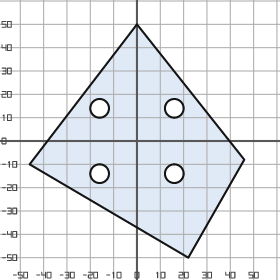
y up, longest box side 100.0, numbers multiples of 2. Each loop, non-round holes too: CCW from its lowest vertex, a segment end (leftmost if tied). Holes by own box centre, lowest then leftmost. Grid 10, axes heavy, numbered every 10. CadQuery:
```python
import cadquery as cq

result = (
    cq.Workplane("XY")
    .moveTo(22.0, -50.0)
    .lineTo(46.0, -8.0)
    .lineTo(0.0, 50.0)
    .lineTo(-46.0, -10.0)
    .close()
    .moveTo(-16.0, -14.0)
    .circle(4.0)
    .moveTo(16.0, -14.0)
    .circle(4.0)
    .moveTo(-16.0, 14.0)
    .circle(4.0)
    .moveTo(16.0, 14.0)
    .circle(4.0)
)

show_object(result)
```